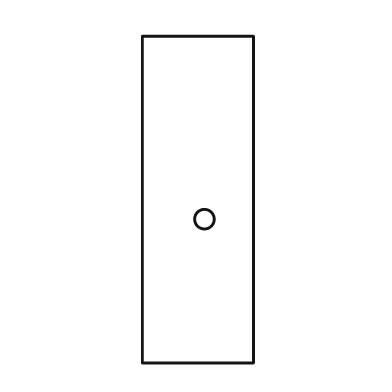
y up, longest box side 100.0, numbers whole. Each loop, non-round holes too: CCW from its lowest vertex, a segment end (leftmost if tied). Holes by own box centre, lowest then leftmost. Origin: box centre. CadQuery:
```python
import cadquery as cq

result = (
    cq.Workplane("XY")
    .moveTo(-17.0, -50.0)
    .lineTo(17.0, -50.0)
    .lineTo(17.0, 50.0)
    .lineTo(-17.0, 50.0)
    .close()
    .moveTo(2.0, -6.0)
    .circle(3.0)
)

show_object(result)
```